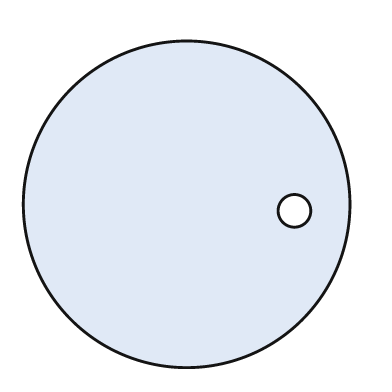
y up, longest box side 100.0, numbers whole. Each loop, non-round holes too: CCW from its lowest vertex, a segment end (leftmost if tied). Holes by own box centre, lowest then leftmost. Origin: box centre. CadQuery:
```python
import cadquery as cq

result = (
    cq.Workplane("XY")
    .moveTo(0.0, 0.0)
    .circle(50.0)
    .moveTo(33.0, -2.0)
    .circle(5.0)
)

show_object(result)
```